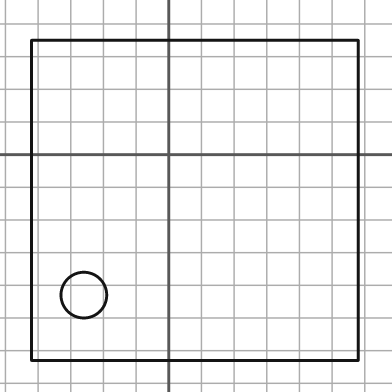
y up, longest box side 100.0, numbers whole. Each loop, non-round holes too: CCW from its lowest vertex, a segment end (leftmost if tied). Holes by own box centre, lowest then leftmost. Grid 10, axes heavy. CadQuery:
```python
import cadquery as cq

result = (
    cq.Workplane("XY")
    .moveTo(-42.0, -63.0)
    .lineTo(58.0, -63.0)
    .lineTo(58.0, 35.0)
    .lineTo(-42.0, 35.0)
    .close()
    .moveTo(-26.0, -43.0)
    .circle(7.0)
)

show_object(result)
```